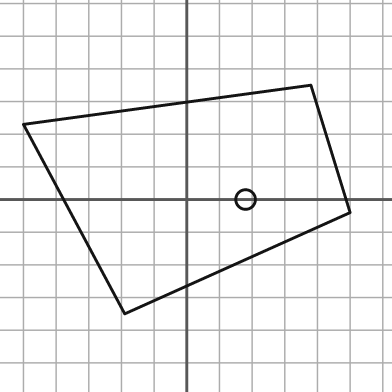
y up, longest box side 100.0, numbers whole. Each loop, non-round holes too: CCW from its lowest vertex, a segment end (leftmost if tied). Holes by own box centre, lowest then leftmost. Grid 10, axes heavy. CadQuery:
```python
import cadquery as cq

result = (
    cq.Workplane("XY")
    .moveTo(-19.0, -35.0)
    .lineTo(50.0, -4.0)
    .lineTo(38.0, 35.0)
    .lineTo(-50.0, 23.0)
    .close()
    .moveTo(18.0, 0.0)
    .circle(3.0)
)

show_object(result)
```